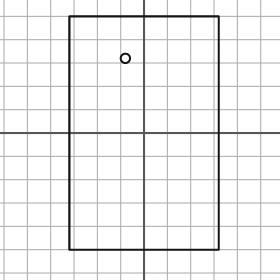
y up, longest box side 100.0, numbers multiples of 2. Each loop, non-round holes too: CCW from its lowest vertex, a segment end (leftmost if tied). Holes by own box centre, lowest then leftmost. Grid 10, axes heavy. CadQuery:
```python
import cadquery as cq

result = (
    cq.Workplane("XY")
    .moveTo(-32.0, -50.0)
    .lineTo(32.0, -50.0)
    .lineTo(32.0, 50.0)
    .lineTo(-32.0, 50.0)
    .close()
    .moveTo(-8.0, 32.0)
    .circle(2.0)
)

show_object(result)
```